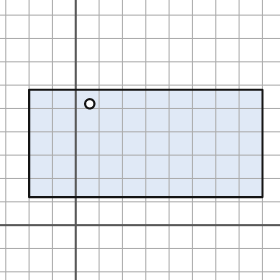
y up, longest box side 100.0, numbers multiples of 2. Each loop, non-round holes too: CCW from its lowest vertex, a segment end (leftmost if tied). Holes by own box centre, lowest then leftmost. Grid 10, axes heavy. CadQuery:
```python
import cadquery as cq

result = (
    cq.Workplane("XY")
    .moveTo(-20.0, 12.0)
    .lineTo(80.0, 12.0)
    .lineTo(80.0, 58.0)
    .lineTo(-20.0, 58.0)
    .close()
    .moveTo(6.0, 52.0)
    .circle(2.0)
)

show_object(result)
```